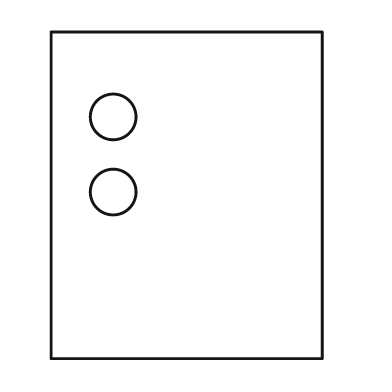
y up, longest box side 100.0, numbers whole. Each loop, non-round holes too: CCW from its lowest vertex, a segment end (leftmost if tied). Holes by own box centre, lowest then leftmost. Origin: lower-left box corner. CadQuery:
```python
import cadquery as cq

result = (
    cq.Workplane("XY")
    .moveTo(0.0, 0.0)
    .lineTo(83.0, 0.0)
    .lineTo(83.0, 100.0)
    .lineTo(0.0, 100.0)
    .close()
    .moveTo(19.0, 51.0)
    .circle(7.0)
    .moveTo(19.0, 74.0)
    .circle(7.0)
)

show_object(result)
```